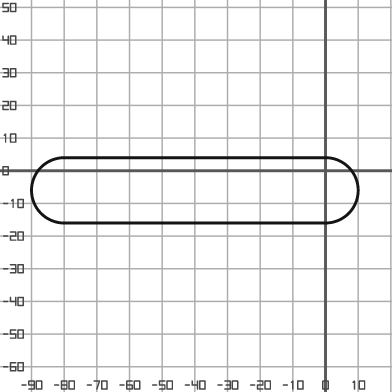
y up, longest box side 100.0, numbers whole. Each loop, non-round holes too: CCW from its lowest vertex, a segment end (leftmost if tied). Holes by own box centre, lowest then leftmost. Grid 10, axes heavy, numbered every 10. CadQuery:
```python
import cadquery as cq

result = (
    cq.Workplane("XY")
    .moveTo(-80.0, -16.0)
    .lineTo(0.0, -16.0)
    .threePointArc((10.0, -6.0), (0.0, 4.0))
    .lineTo(-80.0, 4.0)
    .threePointArc((-90.0, -6.0), (-80.0, -16.0))
    .close()
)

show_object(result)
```